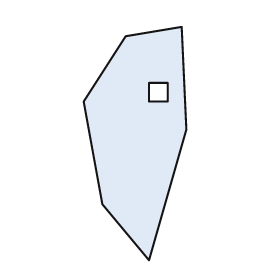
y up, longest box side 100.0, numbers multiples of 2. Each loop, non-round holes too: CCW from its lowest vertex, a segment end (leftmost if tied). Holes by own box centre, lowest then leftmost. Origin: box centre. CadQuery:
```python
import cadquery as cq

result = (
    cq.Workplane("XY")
    .moveTo(6.0, -50.0)
    .lineTo(22.0, 6.0)
    .lineTo(20.0, 50.0)
    .lineTo(-4.0, 46.0)
    .lineTo(-22.0, 18.0)
    .lineTo(-14.0, -26.0)
    .close()
    .moveTo(6.0, 18.0)
    .lineTo(14.0, 18.0)
    .lineTo(14.0, 26.0)
    .lineTo(6.0, 26.0)
    .close()
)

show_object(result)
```